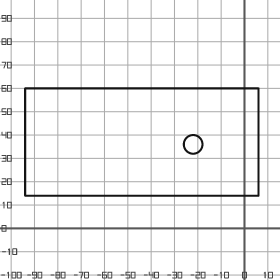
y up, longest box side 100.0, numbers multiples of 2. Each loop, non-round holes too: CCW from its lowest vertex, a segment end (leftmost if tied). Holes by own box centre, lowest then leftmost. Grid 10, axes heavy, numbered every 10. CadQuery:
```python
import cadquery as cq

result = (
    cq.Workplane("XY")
    .moveTo(-94.0, 14.0)
    .lineTo(6.0, 14.0)
    .lineTo(6.0, 60.0)
    .lineTo(-94.0, 60.0)
    .close()
    .moveTo(-22.0, 36.0)
    .circle(4.0)
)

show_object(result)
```